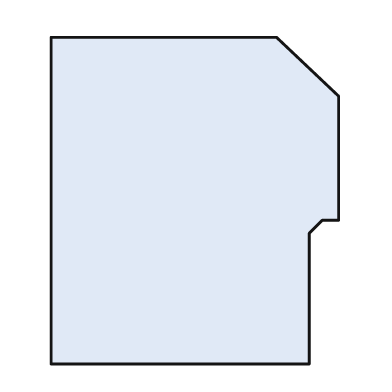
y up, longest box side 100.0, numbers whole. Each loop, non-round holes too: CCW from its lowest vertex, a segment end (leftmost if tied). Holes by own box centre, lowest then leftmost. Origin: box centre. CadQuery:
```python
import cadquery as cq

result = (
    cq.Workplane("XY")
    .moveTo(-44.0, -50.0)
    .lineTo(35.0, -50.0)
    .lineTo(35.0, -10.0)
    .lineTo(39.0, -6.0)
    .lineTo(44.0, -6.0)
    .lineTo(44.0, 32.0)
    .lineTo(25.0, 50.0)
    .lineTo(-44.0, 50.0)
    .close()
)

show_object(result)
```